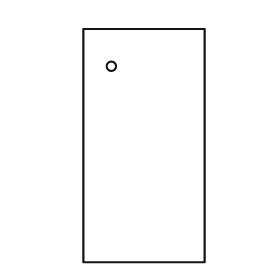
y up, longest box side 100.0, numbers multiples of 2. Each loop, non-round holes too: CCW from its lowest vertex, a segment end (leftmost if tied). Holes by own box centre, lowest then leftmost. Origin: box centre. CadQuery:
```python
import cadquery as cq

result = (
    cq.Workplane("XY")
    .moveTo(-26.0, -50.0)
    .lineTo(26.0, -50.0)
    .lineTo(26.0, 50.0)
    .lineTo(-26.0, 50.0)
    .close()
    .moveTo(-14.0, 34.0)
    .circle(2.0)
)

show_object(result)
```